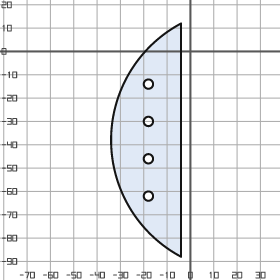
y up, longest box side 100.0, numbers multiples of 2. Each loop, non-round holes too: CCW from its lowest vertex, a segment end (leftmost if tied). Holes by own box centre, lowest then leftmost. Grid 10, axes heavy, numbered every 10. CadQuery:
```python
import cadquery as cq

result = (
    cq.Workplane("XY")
    .moveTo(-4.0, -88.0)
    .lineTo(-4.0, 12.0)
    .threePointArc((-34.0, -38.0), (-4.0, -88.0))
    .close()
    .moveTo(-18.0, -62.0)
    .circle(2.0)
    .moveTo(-18.0, -46.0)
    .circle(2.0)
    .moveTo(-18.0, -30.0)
    .circle(2.0)
    .moveTo(-18.0, -14.0)
    .circle(2.0)
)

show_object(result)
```